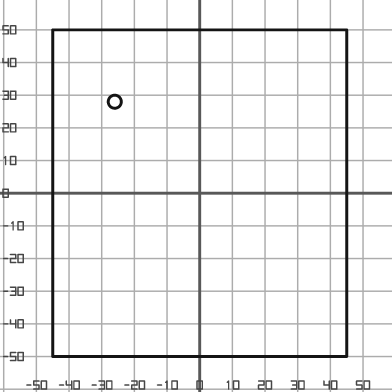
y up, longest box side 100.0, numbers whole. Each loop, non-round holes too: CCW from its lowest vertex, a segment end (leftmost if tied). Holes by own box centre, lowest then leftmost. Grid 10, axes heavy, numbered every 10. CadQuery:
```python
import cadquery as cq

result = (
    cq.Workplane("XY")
    .moveTo(-45.0, -50.0)
    .lineTo(45.0, -50.0)
    .lineTo(45.0, 50.0)
    .lineTo(-45.0, 50.0)
    .close()
    .moveTo(-26.0, 28.0)
    .circle(2.0)
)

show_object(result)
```